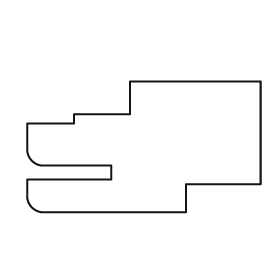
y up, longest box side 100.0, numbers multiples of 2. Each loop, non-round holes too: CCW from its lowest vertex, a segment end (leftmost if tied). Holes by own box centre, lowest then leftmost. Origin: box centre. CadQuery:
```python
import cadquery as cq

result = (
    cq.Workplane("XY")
    .moveTo(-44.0, -28.0)
    .lineTo(18.0, -28.0)
    .lineTo(18.0, -16.0)
    .lineTo(50.0, -16.0)
    .lineTo(50.0, 28.0)
    .lineTo(-6.0, 28.0)
    .lineTo(-6.0, 14.0)
    .lineTo(-30.0, 14.0)
    .lineTo(-30.0, 10.0)
    .lineTo(-50.0, 10.0)
    .lineTo(-50.0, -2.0)
    .threePointArc((-48.0, -6.0), (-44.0, -8.0))
    .lineTo(-14.0, -8.0)
    .lineTo(-14.0, -14.0)
    .lineTo(-50.0, -14.0)
    .lineTo(-50.0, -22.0)
    .threePointArc((-48.0, -26.0), (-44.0, -28.0))
    .close()
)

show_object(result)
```